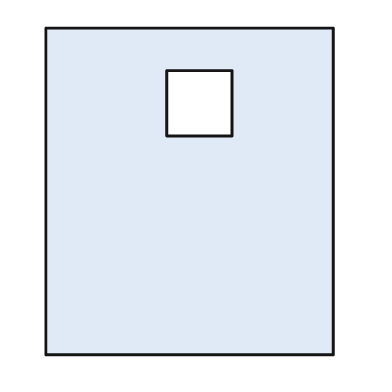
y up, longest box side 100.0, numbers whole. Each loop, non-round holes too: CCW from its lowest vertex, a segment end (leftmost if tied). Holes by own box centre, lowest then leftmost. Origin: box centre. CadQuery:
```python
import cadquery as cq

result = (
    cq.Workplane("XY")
    .moveTo(-44.0, -50.0)
    .lineTo(44.0, -50.0)
    .lineTo(44.0, 50.0)
    .lineTo(-44.0, 50.0)
    .close()
    .moveTo(-7.0, 17.0)
    .lineTo(13.0, 17.0)
    .lineTo(13.0, 37.0)
    .lineTo(-7.0, 37.0)
    .close()
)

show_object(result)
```